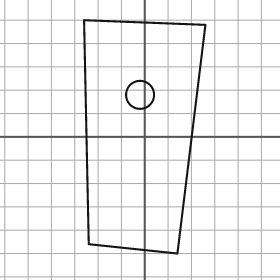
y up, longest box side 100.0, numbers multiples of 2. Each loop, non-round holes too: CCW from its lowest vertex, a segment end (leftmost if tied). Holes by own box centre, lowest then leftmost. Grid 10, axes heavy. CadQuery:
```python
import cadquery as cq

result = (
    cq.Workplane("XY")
    .moveTo(14.0, -50.0)
    .lineTo(26.0, 48.0)
    .lineTo(-26.0, 50.0)
    .lineTo(-24.0, -46.0)
    .close()
    .moveTo(-2.0, 18.0)
    .circle(6.0)
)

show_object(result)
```